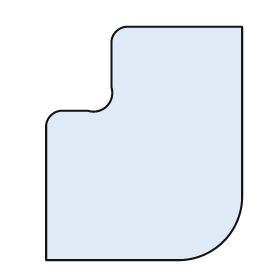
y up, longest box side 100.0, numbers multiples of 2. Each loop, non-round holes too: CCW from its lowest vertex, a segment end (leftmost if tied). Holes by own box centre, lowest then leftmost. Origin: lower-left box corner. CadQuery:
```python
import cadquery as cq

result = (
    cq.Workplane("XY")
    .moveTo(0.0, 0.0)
    .lineTo(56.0, 0.0)
    .threePointArc((76.0, 8.0), (84.0, 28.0))
    .lineTo(84.0, 100.0)
    .lineTo(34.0, 100.0)
    .threePointArc((30.0, 98.0), (28.0, 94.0))
    .lineTo(28.0, 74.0)
    .threePointArc((26.0, 66.0), (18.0, 64.0))
    .lineTo(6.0, 64.0)
    .threePointArc((2.0, 62.0), (0.0, 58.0))
    .close()
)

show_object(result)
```